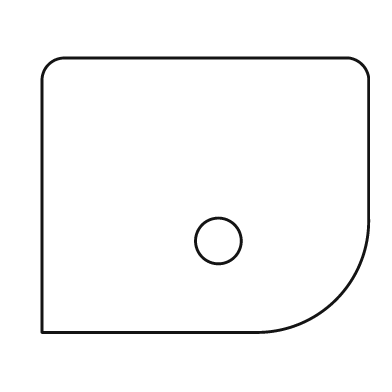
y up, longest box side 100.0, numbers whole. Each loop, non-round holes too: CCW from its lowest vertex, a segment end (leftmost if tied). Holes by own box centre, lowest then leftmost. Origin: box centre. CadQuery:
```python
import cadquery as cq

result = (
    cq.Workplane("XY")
    .moveTo(-50.0, -42.0)
    .lineTo(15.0, -42.0)
    .threePointArc((40.0, -32.0), (50.0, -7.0))
    .lineTo(50.0, 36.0)
    .threePointArc((48.0, 40.0), (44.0, 42.0))
    .lineTo(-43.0, 42.0)
    .threePointArc((-48.0, 40.0), (-50.0, 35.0))
    .close()
    .moveTo(4.0, -14.0)
    .circle(7.0)
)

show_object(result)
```